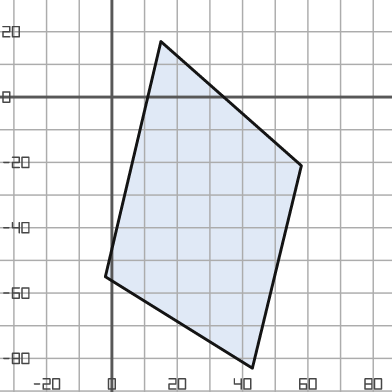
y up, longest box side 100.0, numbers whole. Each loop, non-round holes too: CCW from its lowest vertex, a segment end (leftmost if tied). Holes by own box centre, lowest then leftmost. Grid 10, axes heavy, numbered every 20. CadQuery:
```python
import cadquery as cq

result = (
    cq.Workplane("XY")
    .moveTo(43.0, -83.0)
    .lineTo(58.0, -21.0)
    .lineTo(15.0, 17.0)
    .lineTo(-2.0, -55.0)
    .close()
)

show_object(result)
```